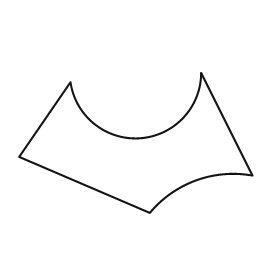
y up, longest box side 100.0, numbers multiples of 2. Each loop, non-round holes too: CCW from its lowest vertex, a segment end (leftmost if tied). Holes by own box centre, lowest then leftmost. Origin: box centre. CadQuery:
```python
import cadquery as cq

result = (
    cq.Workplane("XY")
    .moveTo(6.0, -30.0)
    .threePointArc((26.0, -16.0), (50.0, -14.0))
    .lineTo(28.0, 30.0)
    .threePointArc((2.0, 2.0), (-28.0, 26.0))
    .lineTo(-50.0, -6.0)
    .close()
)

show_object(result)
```